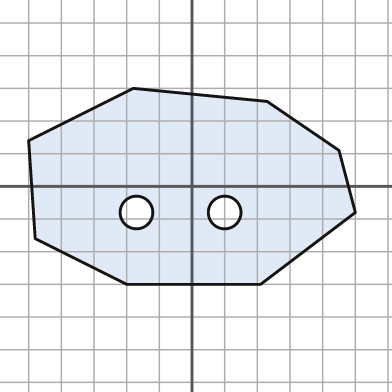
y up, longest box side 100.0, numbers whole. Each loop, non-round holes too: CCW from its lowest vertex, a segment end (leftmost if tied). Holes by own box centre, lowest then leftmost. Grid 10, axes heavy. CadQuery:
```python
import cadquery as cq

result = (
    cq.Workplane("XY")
    .moveTo(-20.0, -30.0)
    .lineTo(21.0, -30.0)
    .lineTo(50.0, -8.0)
    .lineTo(45.0, 11.0)
    .lineTo(23.0, 26.0)
    .lineTo(-18.0, 30.0)
    .lineTo(-50.0, 14.0)
    .lineTo(-48.0, -16.0)
    .close()
    .moveTo(-17.0, -8.0)
    .circle(5.0)
    .moveTo(10.0, -8.0)
    .circle(5.0)
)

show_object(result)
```